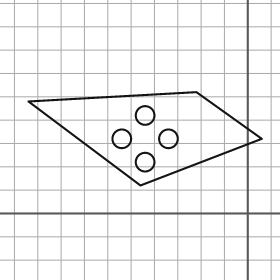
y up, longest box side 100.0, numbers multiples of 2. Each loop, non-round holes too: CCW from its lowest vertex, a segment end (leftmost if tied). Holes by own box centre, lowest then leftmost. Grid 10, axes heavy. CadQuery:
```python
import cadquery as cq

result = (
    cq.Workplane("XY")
    .moveTo(-46.0, 12.0)
    .lineTo(6.0, 32.0)
    .lineTo(-22.0, 52.0)
    .lineTo(-94.0, 48.0)
    .close()
    .moveTo(-44.0, 22.0)
    .circle(4.0)
    .moveTo(-54.0, 32.0)
    .circle(4.0)
    .moveTo(-34.0, 32.0)
    .circle(4.0)
    .moveTo(-44.0, 42.0)
    .circle(4.0)
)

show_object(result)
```